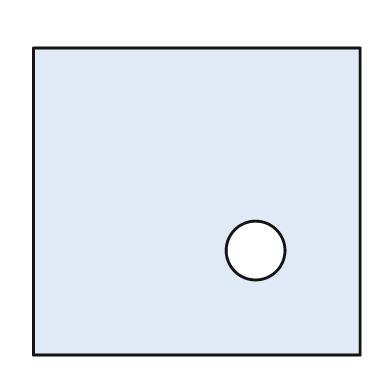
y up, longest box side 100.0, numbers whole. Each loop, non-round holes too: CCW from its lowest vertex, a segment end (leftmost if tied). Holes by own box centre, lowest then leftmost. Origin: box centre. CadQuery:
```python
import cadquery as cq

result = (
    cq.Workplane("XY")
    .moveTo(-50.0, -47.0)
    .lineTo(50.0, -47.0)
    .lineTo(50.0, 47.0)
    .lineTo(-50.0, 47.0)
    .close()
    .moveTo(18.0, -15.0)
    .circle(9.0)
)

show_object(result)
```